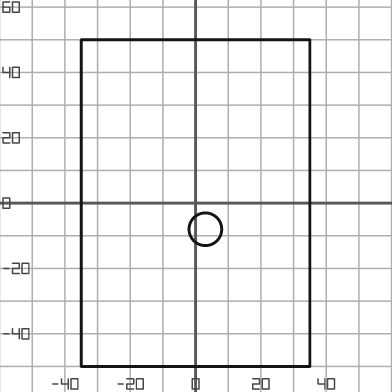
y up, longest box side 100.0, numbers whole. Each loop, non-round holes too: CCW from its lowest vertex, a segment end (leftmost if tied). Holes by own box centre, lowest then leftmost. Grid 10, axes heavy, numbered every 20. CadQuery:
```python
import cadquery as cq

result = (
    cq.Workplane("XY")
    .moveTo(-35.0, -50.0)
    .lineTo(35.0, -50.0)
    .lineTo(35.0, 50.0)
    .lineTo(-35.0, 50.0)
    .close()
    .moveTo(3.0, -8.0)
    .circle(5.0)
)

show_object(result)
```